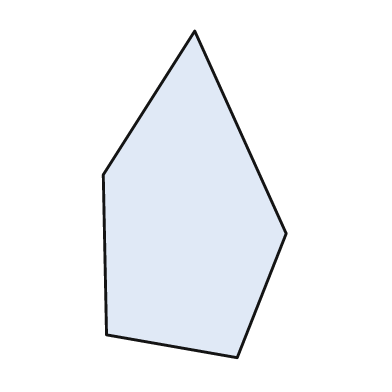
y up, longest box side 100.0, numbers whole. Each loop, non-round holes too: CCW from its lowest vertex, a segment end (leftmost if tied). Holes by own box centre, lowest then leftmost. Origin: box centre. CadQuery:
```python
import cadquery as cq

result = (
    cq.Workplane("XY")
    .moveTo(13.0, -50.0)
    .lineTo(28.0, -12.0)
    .lineTo(0.0, 50.0)
    .lineTo(-28.0, 6.0)
    .lineTo(-27.0, -43.0)
    .close()
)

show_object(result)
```